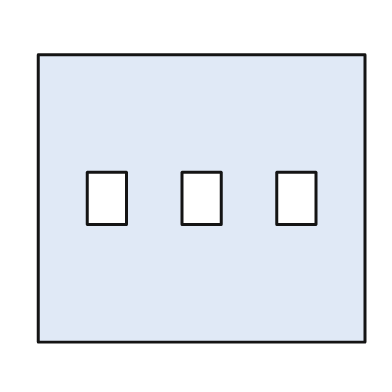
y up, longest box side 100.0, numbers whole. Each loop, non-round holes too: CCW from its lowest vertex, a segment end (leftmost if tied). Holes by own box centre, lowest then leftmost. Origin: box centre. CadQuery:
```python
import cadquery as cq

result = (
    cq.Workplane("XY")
    .moveTo(-50.0, -44.0)
    .lineTo(50.0, -44.0)
    .lineTo(50.0, 44.0)
    .lineTo(-50.0, 44.0)
    .close()
    .moveTo(-35.0, -8.0)
    .lineTo(-23.0, -8.0)
    .lineTo(-23.0, 8.0)
    .lineTo(-35.0, 8.0)
    .close()
    .moveTo(-6.0, -8.0)
    .lineTo(6.0, -8.0)
    .lineTo(6.0, 8.0)
    .lineTo(-6.0, 8.0)
    .close()
    .moveTo(23.0, -8.0)
    .lineTo(35.0, -8.0)
    .lineTo(35.0, 8.0)
    .lineTo(23.0, 8.0)
    .close()
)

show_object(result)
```